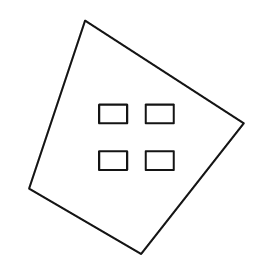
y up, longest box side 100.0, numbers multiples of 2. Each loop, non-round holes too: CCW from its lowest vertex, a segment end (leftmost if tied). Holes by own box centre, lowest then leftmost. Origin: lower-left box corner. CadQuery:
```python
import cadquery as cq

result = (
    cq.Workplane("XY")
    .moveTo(48.0, 0.0)
    .lineTo(92.0, 56.0)
    .lineTo(24.0, 100.0)
    .lineTo(0.0, 28.0)
    .close()
    .moveTo(30.0, 36.0)
    .lineTo(42.0, 36.0)
    .lineTo(42.0, 44.0)
    .lineTo(30.0, 44.0)
    .close()
    .moveTo(50.0, 36.0)
    .lineTo(62.0, 36.0)
    .lineTo(62.0, 44.0)
    .lineTo(50.0, 44.0)
    .close()
    .moveTo(30.0, 56.0)
    .lineTo(42.0, 56.0)
    .lineTo(42.0, 64.0)
    .lineTo(30.0, 64.0)
    .close()
    .moveTo(50.0, 56.0)
    .lineTo(62.0, 56.0)
    .lineTo(62.0, 64.0)
    .lineTo(50.0, 64.0)
    .close()
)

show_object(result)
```